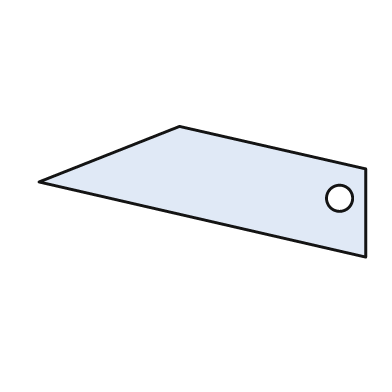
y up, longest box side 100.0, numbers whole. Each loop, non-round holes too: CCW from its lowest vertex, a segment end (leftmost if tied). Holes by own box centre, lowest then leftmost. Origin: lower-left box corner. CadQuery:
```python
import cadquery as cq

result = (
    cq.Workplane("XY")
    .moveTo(100.0, 0.0)
    .lineTo(100.0, 27.0)
    .lineTo(43.0, 40.0)
    .lineTo(0.0, 23.0)
    .close()
    .moveTo(92.0, 18.0)
    .circle(4.0)
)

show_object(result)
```